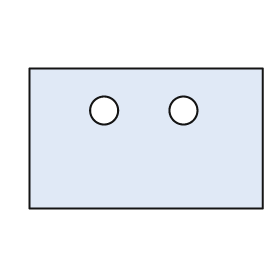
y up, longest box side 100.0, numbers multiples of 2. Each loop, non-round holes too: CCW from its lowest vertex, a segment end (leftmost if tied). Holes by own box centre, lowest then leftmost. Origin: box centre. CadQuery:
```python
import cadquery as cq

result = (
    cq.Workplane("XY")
    .moveTo(-50.0, -30.0)
    .lineTo(50.0, -30.0)
    .lineTo(50.0, 30.0)
    .lineTo(-50.0, 30.0)
    .close()
    .moveTo(-18.0, 12.0)
    .circle(6.0)
    .moveTo(16.0, 12.0)
    .circle(6.0)
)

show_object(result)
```